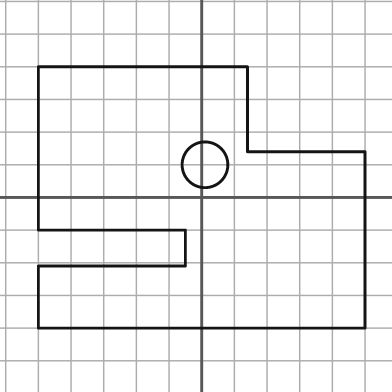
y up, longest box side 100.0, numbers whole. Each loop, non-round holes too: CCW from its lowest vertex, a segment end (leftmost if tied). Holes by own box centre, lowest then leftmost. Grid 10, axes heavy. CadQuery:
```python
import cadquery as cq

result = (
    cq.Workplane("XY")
    .moveTo(-50.0, -40.0)
    .lineTo(50.0, -40.0)
    .lineTo(50.0, 14.0)
    .lineTo(14.0, 14.0)
    .lineTo(14.0, 40.0)
    .lineTo(-50.0, 40.0)
    .lineTo(-50.0, -10.0)
    .lineTo(-5.0, -10.0)
    .lineTo(-5.0, -21.0)
    .lineTo(-50.0, -21.0)
    .close()
    .moveTo(1.0, 10.0)
    .circle(7.0)
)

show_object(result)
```